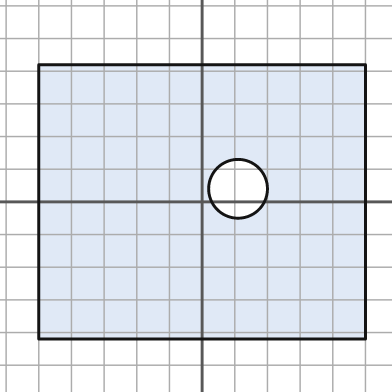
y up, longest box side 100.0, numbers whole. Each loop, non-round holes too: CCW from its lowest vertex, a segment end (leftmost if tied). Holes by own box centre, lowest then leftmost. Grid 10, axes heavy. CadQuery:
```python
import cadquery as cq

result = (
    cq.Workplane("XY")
    .moveTo(-50.0, -42.0)
    .lineTo(50.0, -42.0)
    .lineTo(50.0, 42.0)
    .lineTo(-50.0, 42.0)
    .close()
    .moveTo(11.0, 4.0)
    .circle(9.0)
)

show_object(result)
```